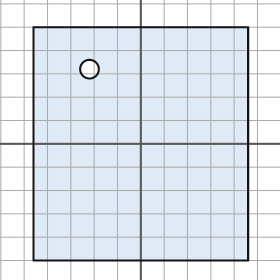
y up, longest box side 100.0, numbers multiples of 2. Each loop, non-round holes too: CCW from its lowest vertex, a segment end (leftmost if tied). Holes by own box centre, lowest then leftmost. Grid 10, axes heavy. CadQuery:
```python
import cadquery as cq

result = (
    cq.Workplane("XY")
    .moveTo(-46.0, -50.0)
    .lineTo(46.0, -50.0)
    .lineTo(46.0, 50.0)
    .lineTo(-46.0, 50.0)
    .close()
    .moveTo(-22.0, 32.0)
    .circle(4.0)
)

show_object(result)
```